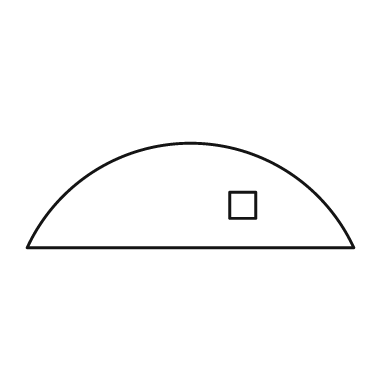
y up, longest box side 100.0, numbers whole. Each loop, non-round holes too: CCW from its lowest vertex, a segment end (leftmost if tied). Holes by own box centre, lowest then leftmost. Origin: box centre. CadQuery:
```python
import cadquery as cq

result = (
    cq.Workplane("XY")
    .moveTo(-50.0, -16.0)
    .lineTo(50.0, -16.0)
    .threePointArc((0.0, 16.0), (-50.0, -16.0))
    .close()
    .moveTo(12.0, -7.0)
    .lineTo(20.0, -7.0)
    .lineTo(20.0, 1.0)
    .lineTo(12.0, 1.0)
    .close()
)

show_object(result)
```